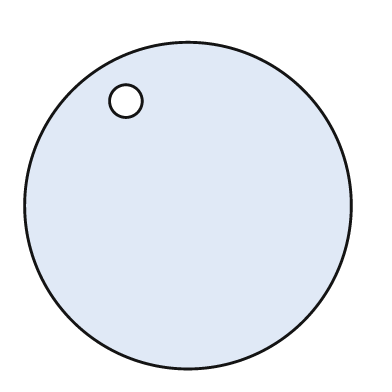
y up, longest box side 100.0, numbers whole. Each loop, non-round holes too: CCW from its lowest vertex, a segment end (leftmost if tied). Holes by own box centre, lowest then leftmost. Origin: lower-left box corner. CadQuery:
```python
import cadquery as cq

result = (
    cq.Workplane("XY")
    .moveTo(50.0, 50.0)
    .circle(50.0)
    .moveTo(31.0, 82.0)
    .circle(5.0)
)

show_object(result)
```